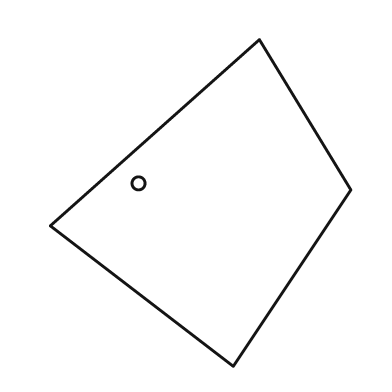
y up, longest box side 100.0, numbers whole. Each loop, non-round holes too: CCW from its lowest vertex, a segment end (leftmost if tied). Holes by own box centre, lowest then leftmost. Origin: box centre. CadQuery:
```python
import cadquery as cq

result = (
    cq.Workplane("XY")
    .moveTo(10.0, -50.0)
    .lineTo(46.0, 4.0)
    .lineTo(18.0, 50.0)
    .lineTo(-46.0, -7.0)
    .close()
    .moveTo(-19.0, 6.0)
    .circle(2.0)
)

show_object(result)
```